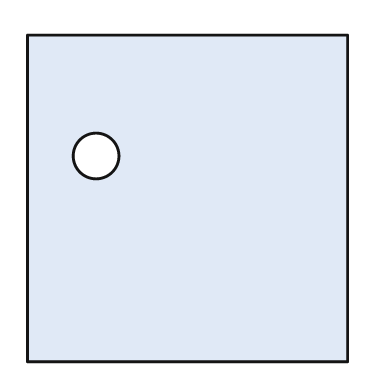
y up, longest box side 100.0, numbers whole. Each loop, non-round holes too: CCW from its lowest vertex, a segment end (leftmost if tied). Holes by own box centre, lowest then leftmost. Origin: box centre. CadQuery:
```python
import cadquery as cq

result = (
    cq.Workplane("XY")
    .moveTo(-49.0, -50.0)
    .lineTo(49.0, -50.0)
    .lineTo(49.0, 50.0)
    .lineTo(-49.0, 50.0)
    .close()
    .moveTo(-28.0, 13.0)
    .circle(7.0)
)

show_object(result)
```